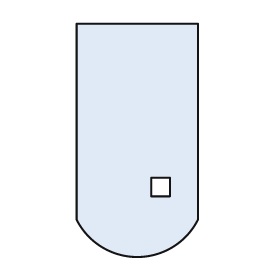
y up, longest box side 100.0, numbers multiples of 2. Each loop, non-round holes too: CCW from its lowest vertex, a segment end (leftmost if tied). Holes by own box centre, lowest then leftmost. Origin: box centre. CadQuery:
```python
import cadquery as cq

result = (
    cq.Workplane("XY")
    .moveTo(-26.0, -34.0)
    .threePointArc((0.0, -50.0), (26.0, -34.0))
    .lineTo(26.0, 50.0)
    .lineTo(-26.0, 50.0)
    .close()
    .moveTo(6.0, -24.0)
    .lineTo(14.0, -24.0)
    .lineTo(14.0, -16.0)
    .lineTo(6.0, -16.0)
    .close()
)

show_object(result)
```